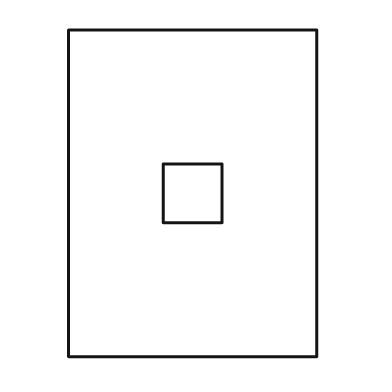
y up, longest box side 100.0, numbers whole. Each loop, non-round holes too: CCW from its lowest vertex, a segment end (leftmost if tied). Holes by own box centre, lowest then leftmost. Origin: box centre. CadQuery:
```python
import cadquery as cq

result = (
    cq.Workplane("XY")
    .moveTo(-38.0, -50.0)
    .lineTo(38.0, -50.0)
    .lineTo(38.0, 50.0)
    .lineTo(-38.0, 50.0)
    .close()
    .moveTo(-9.0, -9.0)
    .lineTo(9.0, -9.0)
    .lineTo(9.0, 9.0)
    .lineTo(-9.0, 9.0)
    .close()
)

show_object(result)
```